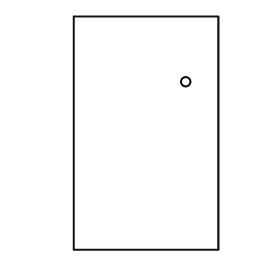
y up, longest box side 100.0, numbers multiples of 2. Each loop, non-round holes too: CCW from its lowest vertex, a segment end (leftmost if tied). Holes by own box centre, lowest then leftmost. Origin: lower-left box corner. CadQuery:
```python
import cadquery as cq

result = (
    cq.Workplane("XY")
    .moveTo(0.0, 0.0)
    .lineTo(62.0, 0.0)
    .lineTo(62.0, 100.0)
    .lineTo(0.0, 100.0)
    .close()
    .moveTo(48.0, 72.0)
    .circle(2.0)
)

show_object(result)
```